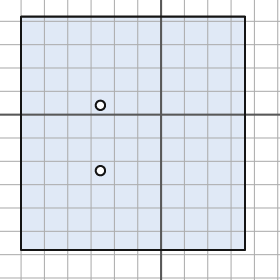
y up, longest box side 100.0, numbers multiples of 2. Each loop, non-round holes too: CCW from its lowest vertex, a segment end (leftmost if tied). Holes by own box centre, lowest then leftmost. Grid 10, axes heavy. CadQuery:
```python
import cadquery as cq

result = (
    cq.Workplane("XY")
    .moveTo(-60.0, -58.0)
    .lineTo(36.0, -58.0)
    .lineTo(36.0, 42.0)
    .lineTo(-60.0, 42.0)
    .close()
    .moveTo(-26.0, -24.0)
    .circle(2.0)
    .moveTo(-26.0, 4.0)
    .circle(2.0)
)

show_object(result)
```